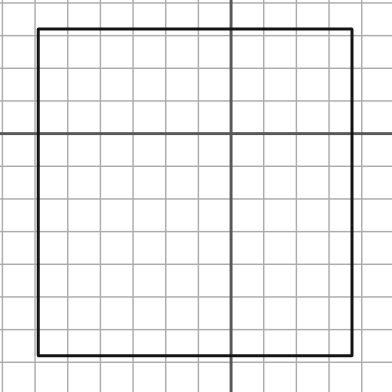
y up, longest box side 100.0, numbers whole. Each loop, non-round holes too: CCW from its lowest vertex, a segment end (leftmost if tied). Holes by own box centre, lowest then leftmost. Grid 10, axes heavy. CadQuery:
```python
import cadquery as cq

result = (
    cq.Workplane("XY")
    .moveTo(-59.0, -68.0)
    .lineTo(37.0, -68.0)
    .lineTo(37.0, 32.0)
    .lineTo(-59.0, 32.0)
    .close()
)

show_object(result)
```